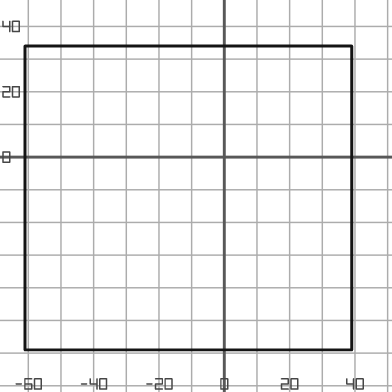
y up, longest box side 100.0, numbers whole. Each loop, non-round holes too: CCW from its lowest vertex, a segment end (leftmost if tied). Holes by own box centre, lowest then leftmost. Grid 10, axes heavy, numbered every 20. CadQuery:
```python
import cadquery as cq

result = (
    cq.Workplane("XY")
    .moveTo(-61.0, -59.0)
    .lineTo(39.0, -59.0)
    .lineTo(39.0, 34.0)
    .lineTo(-61.0, 34.0)
    .close()
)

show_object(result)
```